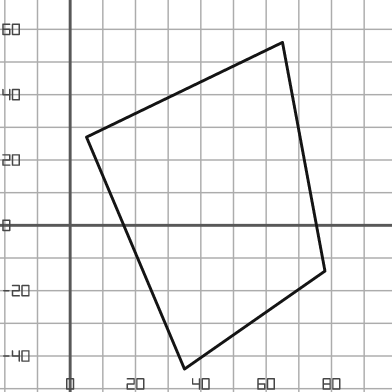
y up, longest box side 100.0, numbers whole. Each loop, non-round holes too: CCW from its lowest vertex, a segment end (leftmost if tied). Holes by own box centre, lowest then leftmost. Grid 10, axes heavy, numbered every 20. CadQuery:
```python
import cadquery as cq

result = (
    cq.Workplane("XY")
    .moveTo(35.0, -44.0)
    .lineTo(78.0, -14.0)
    .lineTo(65.0, 56.0)
    .lineTo(5.0, 27.0)
    .close()
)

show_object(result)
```